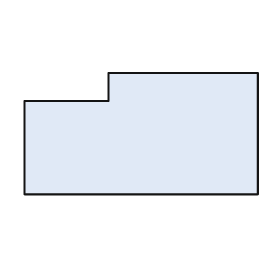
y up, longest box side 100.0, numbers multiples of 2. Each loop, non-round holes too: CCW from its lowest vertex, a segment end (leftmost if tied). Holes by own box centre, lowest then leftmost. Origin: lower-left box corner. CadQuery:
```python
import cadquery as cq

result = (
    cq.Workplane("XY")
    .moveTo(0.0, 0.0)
    .lineTo(100.0, 0.0)
    .lineTo(100.0, 52.0)
    .lineTo(36.0, 52.0)
    .lineTo(36.0, 40.0)
    .lineTo(0.0, 40.0)
    .close()
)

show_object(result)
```